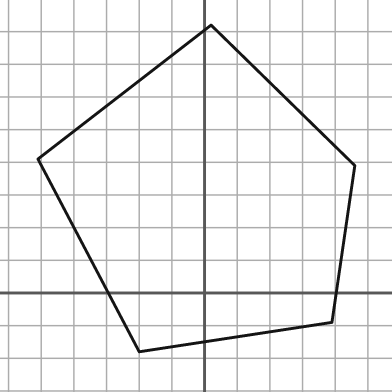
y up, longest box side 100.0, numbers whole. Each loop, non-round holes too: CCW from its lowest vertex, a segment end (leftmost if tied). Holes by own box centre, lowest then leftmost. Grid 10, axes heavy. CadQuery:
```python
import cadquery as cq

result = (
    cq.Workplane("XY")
    .moveTo(-20.0, -18.0)
    .lineTo(39.0, -9.0)
    .lineTo(46.0, 39.0)
    .lineTo(2.0, 82.0)
    .lineTo(-51.0, 41.0)
    .close()
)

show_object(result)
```